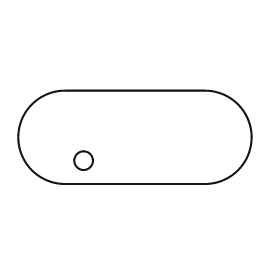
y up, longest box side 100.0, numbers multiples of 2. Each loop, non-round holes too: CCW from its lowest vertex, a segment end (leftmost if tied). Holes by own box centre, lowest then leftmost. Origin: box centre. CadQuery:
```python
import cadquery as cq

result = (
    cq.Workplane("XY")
    .moveTo(-30.0, -20.0)
    .lineTo(30.0, -20.0)
    .threePointArc((50.0, 0.0), (30.0, 20.0))
    .lineTo(-30.0, 20.0)
    .threePointArc((-50.0, 0.0), (-30.0, -20.0))
    .close()
    .moveTo(-22.0, -10.0)
    .circle(4.0)
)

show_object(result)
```